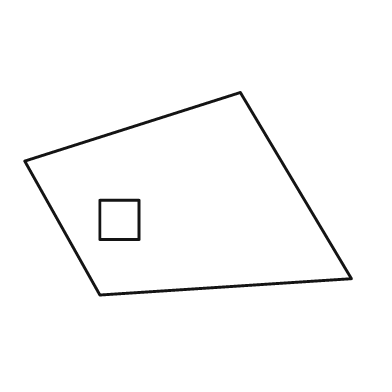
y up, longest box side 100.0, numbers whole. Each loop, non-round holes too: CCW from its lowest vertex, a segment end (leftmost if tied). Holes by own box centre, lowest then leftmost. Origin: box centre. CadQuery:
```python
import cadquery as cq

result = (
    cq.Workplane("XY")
    .moveTo(-27.0, -31.0)
    .lineTo(50.0, -26.0)
    .lineTo(16.0, 31.0)
    .lineTo(-50.0, 10.0)
    .close()
    .moveTo(-27.0, -14.0)
    .lineTo(-15.0, -14.0)
    .lineTo(-15.0, -2.0)
    .lineTo(-27.0, -2.0)
    .close()
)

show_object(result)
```